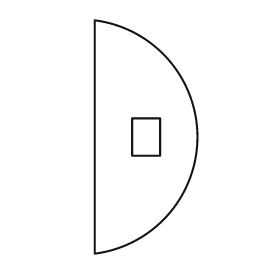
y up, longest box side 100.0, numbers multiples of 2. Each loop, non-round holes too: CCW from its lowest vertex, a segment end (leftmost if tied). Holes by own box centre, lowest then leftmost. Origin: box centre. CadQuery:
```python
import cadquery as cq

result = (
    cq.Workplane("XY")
    .moveTo(-22.0, -50.0)
    .threePointArc((22.0, 0.0), (-22.0, 50.0))
    .close()
    .moveTo(-6.0, -8.0)
    .lineTo(6.0, -8.0)
    .lineTo(6.0, 8.0)
    .lineTo(-6.0, 8.0)
    .close()
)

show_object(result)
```